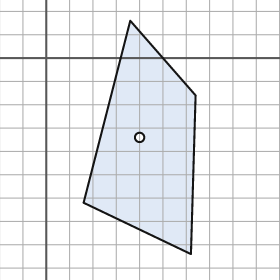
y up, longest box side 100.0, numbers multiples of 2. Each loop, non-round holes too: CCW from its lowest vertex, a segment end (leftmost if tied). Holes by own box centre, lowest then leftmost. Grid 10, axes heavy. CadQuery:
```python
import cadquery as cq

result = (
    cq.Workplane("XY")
    .moveTo(62.0, -84.0)
    .lineTo(64.0, -16.0)
    .lineTo(36.0, 16.0)
    .lineTo(16.0, -62.0)
    .close()
    .moveTo(40.0, -34.0)
    .circle(2.0)
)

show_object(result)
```